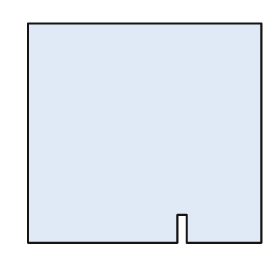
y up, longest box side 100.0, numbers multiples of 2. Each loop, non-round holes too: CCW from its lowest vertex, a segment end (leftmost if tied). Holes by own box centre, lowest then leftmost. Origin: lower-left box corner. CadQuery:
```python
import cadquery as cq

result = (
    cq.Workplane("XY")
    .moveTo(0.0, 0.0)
    .lineTo(64.0, 0.0)
    .lineTo(64.0, 12.0)
    .lineTo(68.0, 12.0)
    .lineTo(68.0, 0.0)
    .lineTo(100.0, 0.0)
    .lineTo(100.0, 94.0)
    .lineTo(0.0, 94.0)
    .close()
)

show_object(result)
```